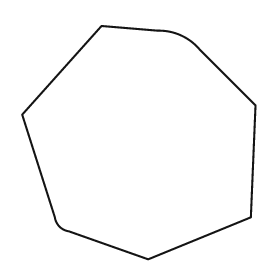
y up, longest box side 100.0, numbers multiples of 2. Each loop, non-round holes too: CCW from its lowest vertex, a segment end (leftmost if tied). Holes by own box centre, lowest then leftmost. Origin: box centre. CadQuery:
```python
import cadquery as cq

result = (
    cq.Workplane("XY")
    .moveTo(4.0, -50.0)
    .lineTo(48.0, -32.0)
    .lineTo(50.0, 16.0)
    .lineTo(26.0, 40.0)
    .threePointArc((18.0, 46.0), (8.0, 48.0))
    .lineTo(-16.0, 50.0)
    .lineTo(-50.0, 12.0)
    .lineTo(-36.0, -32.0)
    .threePointArc((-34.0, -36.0), (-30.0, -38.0))
    .close()
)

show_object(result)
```